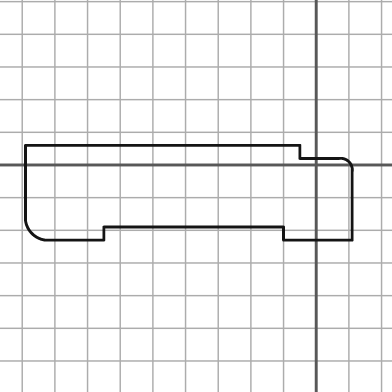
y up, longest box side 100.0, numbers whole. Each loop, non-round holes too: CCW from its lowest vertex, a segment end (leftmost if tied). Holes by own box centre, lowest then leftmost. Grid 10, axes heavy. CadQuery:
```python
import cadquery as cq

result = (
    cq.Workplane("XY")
    .moveTo(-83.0, -23.0)
    .lineTo(-65.0, -23.0)
    .lineTo(-65.0, -19.0)
    .lineTo(-10.0, -19.0)
    .lineTo(-10.0, -23.0)
    .lineTo(11.0, -23.0)
    .lineTo(11.0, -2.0)
    .threePointArc((10.0, 1.0), (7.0, 2.0))
    .lineTo(-5.0, 2.0)
    .lineTo(-5.0, 6.0)
    .lineTo(-89.0, 6.0)
    .lineTo(-89.0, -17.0)
    .threePointArc((-87.0, -21.0), (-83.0, -23.0))
    .close()
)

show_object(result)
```